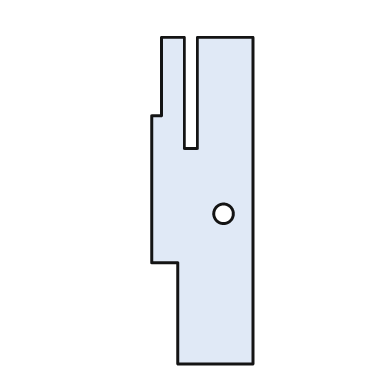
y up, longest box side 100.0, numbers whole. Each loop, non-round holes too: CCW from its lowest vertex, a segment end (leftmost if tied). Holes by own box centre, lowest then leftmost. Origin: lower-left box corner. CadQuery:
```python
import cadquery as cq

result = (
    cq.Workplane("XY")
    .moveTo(8.0, 0.0)
    .lineTo(31.0, 0.0)
    .lineTo(31.0, 100.0)
    .lineTo(14.0, 100.0)
    .lineTo(14.0, 66.0)
    .lineTo(10.0, 66.0)
    .lineTo(10.0, 100.0)
    .lineTo(3.0, 100.0)
    .lineTo(3.0, 76.0)
    .lineTo(0.0, 76.0)
    .lineTo(0.0, 31.0)
    .lineTo(8.0, 31.0)
    .close()
    .moveTo(22.0, 46.0)
    .circle(3.0)
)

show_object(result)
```